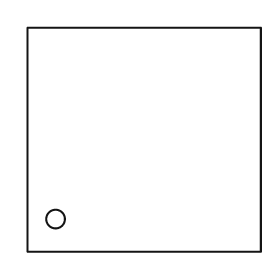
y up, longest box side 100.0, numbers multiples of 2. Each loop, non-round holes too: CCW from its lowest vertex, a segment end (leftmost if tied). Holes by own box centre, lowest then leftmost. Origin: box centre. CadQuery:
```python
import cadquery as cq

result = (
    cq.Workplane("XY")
    .moveTo(-50.0, -48.0)
    .lineTo(50.0, -48.0)
    .lineTo(50.0, 48.0)
    .lineTo(-50.0, 48.0)
    .close()
    .moveTo(-38.0, -34.0)
    .circle(4.0)
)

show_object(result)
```